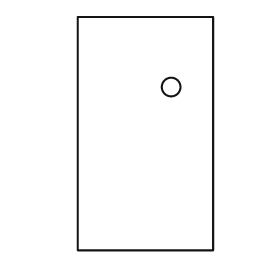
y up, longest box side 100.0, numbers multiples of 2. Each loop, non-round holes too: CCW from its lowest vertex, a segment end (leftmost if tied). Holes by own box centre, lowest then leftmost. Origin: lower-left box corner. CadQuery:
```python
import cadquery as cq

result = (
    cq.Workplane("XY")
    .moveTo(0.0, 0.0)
    .lineTo(58.0, 0.0)
    .lineTo(58.0, 100.0)
    .lineTo(0.0, 100.0)
    .close()
    .moveTo(40.0, 70.0)
    .circle(4.0)
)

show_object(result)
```